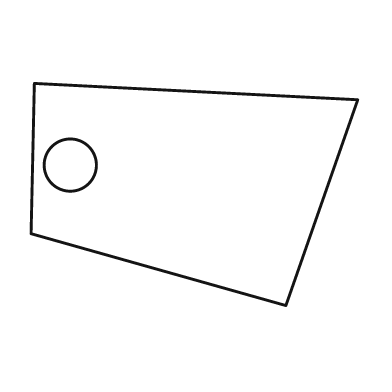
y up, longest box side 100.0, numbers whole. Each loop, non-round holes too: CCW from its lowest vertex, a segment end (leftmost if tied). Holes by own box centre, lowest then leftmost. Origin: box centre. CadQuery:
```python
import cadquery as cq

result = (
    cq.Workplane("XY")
    .moveTo(28.0, -34.0)
    .lineTo(50.0, 29.0)
    .lineTo(-49.0, 34.0)
    .lineTo(-50.0, -12.0)
    .close()
    .moveTo(-38.0, 9.0)
    .circle(8.0)
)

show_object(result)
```